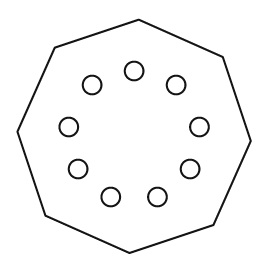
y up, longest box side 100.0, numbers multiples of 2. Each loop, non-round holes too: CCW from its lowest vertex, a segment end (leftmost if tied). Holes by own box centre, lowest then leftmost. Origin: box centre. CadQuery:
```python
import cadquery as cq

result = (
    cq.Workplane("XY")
    .moveTo(-2.0, -50.0)
    .lineTo(34.0, -38.0)
    .lineTo(50.0, -2.0)
    .lineTo(38.0, 34.0)
    .lineTo(2.0, 50.0)
    .lineTo(-34.0, 38.0)
    .lineTo(-50.0, 2.0)
    .lineTo(-38.0, -34.0)
    .close()
    .moveTo(-10.0, -26.0)
    .circle(4.0)
    .moveTo(10.0, -26.0)
    .circle(4.0)
    .moveTo(-24.0, -14.0)
    .circle(4.0)
    .moveTo(24.0, -14.0)
    .circle(4.0)
    .moveTo(-28.0, 4.0)
    .circle(4.0)
    .moveTo(28.0, 4.0)
    .circle(4.0)
    .moveTo(-18.0, 22.0)
    .circle(4.0)
    .moveTo(18.0, 22.0)
    .circle(4.0)
    .moveTo(0.0, 28.0)
    .circle(4.0)
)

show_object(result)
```